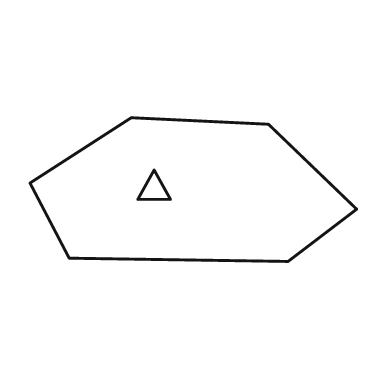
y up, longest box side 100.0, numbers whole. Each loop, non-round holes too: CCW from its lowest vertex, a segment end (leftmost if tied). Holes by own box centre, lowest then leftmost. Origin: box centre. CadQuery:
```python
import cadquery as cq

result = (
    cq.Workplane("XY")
    .moveTo(29.0, -22.0)
    .lineTo(50.0, -6.0)
    .lineTo(23.0, 20.0)
    .lineTo(-19.0, 22.0)
    .lineTo(-50.0, 2.0)
    .lineTo(-38.0, -21.0)
    .close()
    .moveTo(-17.0, -3.0)
    .lineTo(-7.0, -3.0)
    .lineTo(-12.0, 6.0)
    .close()
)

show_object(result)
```